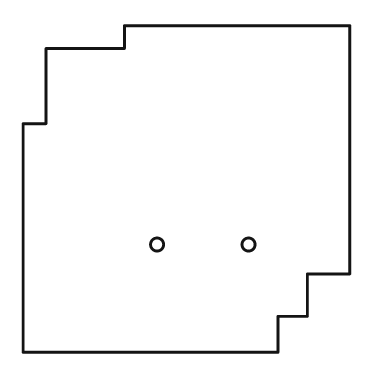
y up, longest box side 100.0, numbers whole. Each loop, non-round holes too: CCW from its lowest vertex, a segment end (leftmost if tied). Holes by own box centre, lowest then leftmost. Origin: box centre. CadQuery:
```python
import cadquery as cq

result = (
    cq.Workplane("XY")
    .moveTo(-50.0, -50.0)
    .lineTo(28.0, -50.0)
    .lineTo(28.0, -39.0)
    .lineTo(37.0, -39.0)
    .lineTo(37.0, -26.0)
    .lineTo(50.0, -26.0)
    .lineTo(50.0, 50.0)
    .lineTo(-19.0, 50.0)
    .lineTo(-19.0, 43.0)
    .lineTo(-43.0, 43.0)
    .lineTo(-43.0, 20.0)
    .lineTo(-50.0, 20.0)
    .close()
    .moveTo(-9.0, -17.0)
    .circle(2.0)
    .moveTo(19.0, -17.0)
    .circle(2.0)
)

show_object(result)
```